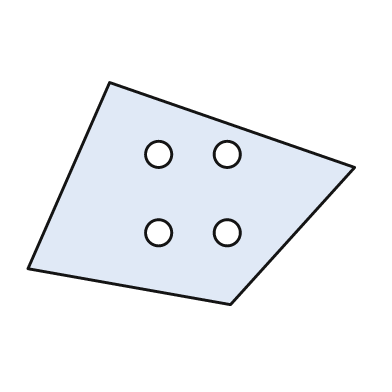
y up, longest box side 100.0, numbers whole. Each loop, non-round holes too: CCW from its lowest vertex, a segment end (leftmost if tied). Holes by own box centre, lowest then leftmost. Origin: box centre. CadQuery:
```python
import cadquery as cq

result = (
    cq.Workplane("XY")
    .moveTo(12.0, -34.0)
    .lineTo(50.0, 8.0)
    .lineTo(-25.0, 34.0)
    .lineTo(-50.0, -23.0)
    .close()
    .moveTo(-10.0, -12.0)
    .circle(4.0)
    .moveTo(11.0, -12.0)
    .circle(4.0)
    .moveTo(-10.0, 12.0)
    .circle(4.0)
    .moveTo(11.0, 12.0)
    .circle(4.0)
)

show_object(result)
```